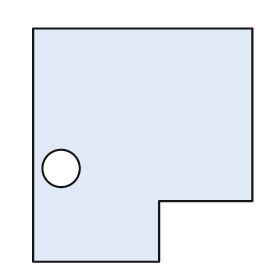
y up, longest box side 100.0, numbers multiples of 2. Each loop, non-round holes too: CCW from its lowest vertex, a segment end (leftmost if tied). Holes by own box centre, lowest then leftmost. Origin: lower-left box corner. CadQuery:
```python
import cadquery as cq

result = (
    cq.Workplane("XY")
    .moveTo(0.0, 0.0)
    .lineTo(54.0, 0.0)
    .lineTo(54.0, 26.0)
    .lineTo(94.0, 26.0)
    .lineTo(94.0, 100.0)
    .lineTo(0.0, 100.0)
    .close()
    .moveTo(12.0, 40.0)
    .circle(8.0)
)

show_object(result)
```